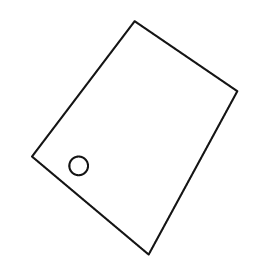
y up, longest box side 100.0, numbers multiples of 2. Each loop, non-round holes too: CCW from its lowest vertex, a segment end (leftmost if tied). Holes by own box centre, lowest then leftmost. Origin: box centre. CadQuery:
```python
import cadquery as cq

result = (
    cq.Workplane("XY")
    .moveTo(6.0, -50.0)
    .lineTo(44.0, 20.0)
    .lineTo(0.0, 50.0)
    .lineTo(-44.0, -8.0)
    .close()
    .moveTo(-24.0, -12.0)
    .circle(4.0)
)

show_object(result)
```